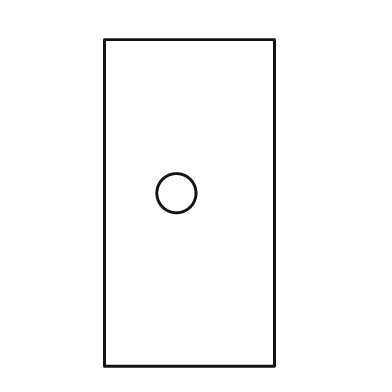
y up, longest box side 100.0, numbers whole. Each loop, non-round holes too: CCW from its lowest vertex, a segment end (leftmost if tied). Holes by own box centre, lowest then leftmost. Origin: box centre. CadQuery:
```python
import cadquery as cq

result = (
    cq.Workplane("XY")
    .moveTo(-26.0, -50.0)
    .lineTo(26.0, -50.0)
    .lineTo(26.0, 50.0)
    .lineTo(-26.0, 50.0)
    .close()
    .moveTo(-4.0, 3.0)
    .circle(6.0)
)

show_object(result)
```